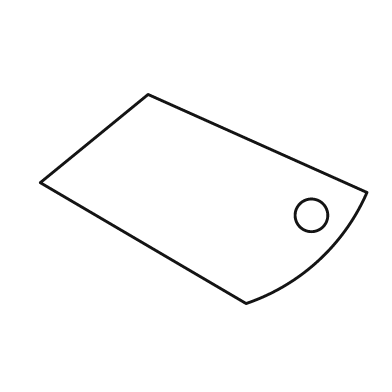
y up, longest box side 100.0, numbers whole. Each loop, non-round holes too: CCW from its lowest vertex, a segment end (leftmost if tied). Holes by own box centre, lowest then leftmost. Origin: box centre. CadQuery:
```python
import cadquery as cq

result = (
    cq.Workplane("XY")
    .moveTo(13.0, -32.0)
    .threePointArc((35.0, -19.0), (50.0, 2.0))
    .lineTo(-17.0, 32.0)
    .lineTo(-50.0, 5.0)
    .close()
    .moveTo(33.0, -5.0)
    .circle(5.0)
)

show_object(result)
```